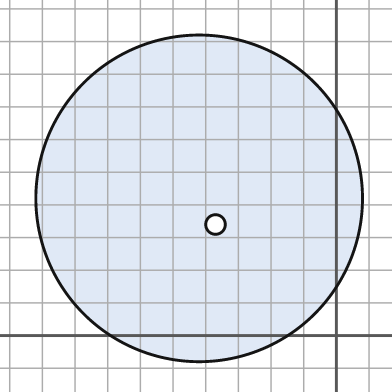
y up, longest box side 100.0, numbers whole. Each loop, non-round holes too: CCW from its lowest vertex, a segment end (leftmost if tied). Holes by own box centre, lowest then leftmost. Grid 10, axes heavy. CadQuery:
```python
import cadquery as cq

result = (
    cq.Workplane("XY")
    .moveTo(-42.0, 42.0)
    .circle(50.0)
    .moveTo(-37.0, 34.0)
    .circle(3.0)
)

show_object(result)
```